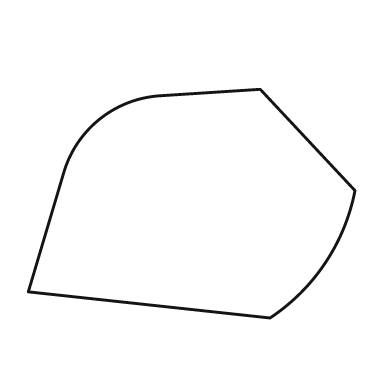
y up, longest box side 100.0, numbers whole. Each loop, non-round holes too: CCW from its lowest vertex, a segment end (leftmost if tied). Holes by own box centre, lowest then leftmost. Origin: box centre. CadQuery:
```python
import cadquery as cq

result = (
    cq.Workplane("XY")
    .moveTo(24.0, -35.0)
    .threePointArc((41.0, -18.0), (50.0, 4.0))
    .lineTo(21.0, 35.0)
    .lineTo(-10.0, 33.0)
    .threePointArc((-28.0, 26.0), (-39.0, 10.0))
    .lineTo(-50.0, -27.0)
    .close()
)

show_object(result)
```